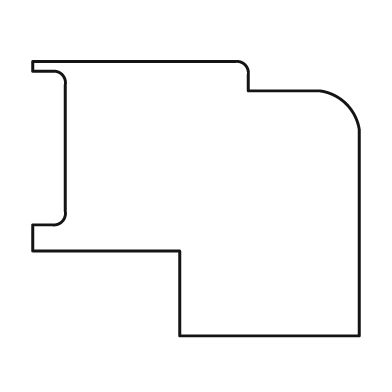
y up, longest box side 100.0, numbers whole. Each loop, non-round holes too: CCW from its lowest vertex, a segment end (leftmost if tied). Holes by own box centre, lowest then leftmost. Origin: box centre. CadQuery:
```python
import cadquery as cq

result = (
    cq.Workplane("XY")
    .moveTo(-5.0, -42.0)
    .lineTo(50.0, -42.0)
    .lineTo(50.0, 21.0)
    .threePointArc((46.0, 29.0), (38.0, 33.0))
    .lineTo(16.0, 33.0)
    .lineTo(16.0, 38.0)
    .threePointArc((15.0, 41.0), (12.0, 42.0))
    .lineTo(-50.0, 42.0)
    .lineTo(-50.0, 39.0)
    .lineTo(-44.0, 39.0)
    .threePointArc((-41.0, 38.0), (-40.0, 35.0))
    .lineTo(-40.0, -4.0)
    .threePointArc((-41.0, -7.0), (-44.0, -8.0))
    .lineTo(-50.0, -8.0)
    .lineTo(-50.0, -16.0)
    .lineTo(-5.0, -16.0)
    .close()
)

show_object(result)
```